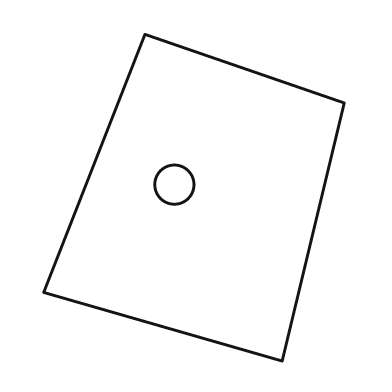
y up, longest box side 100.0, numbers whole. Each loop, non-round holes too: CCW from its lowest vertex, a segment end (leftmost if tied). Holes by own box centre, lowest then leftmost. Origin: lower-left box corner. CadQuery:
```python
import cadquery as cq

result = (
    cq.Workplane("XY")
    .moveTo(73.0, 0.0)
    .lineTo(92.0, 79.0)
    .lineTo(31.0, 100.0)
    .lineTo(0.0, 21.0)
    .close()
    .moveTo(40.0, 54.0)
    .circle(6.0)
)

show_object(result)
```